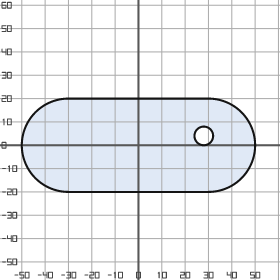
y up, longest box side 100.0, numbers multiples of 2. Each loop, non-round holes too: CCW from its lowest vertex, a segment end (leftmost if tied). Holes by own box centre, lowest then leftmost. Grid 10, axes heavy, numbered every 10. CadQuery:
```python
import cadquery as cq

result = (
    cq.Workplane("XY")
    .moveTo(-30.0, -20.0)
    .lineTo(30.0, -20.0)
    .threePointArc((50.0, 0.0), (30.0, 20.0))
    .lineTo(-30.0, 20.0)
    .threePointArc((-50.0, 0.0), (-30.0, -20.0))
    .close()
    .moveTo(28.0, 4.0)
    .circle(4.0)
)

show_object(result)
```